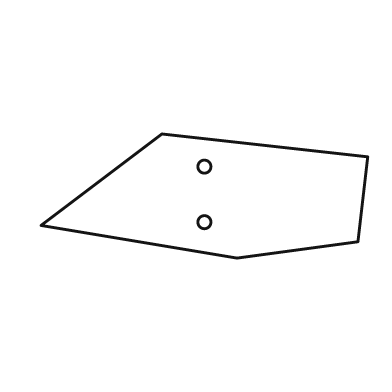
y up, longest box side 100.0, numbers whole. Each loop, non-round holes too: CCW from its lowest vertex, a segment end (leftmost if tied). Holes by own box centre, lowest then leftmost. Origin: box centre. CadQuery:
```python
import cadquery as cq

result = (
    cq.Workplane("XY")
    .moveTo(10.0, -19.0)
    .lineTo(47.0, -14.0)
    .lineTo(50.0, 12.0)
    .lineTo(-13.0, 19.0)
    .lineTo(-50.0, -9.0)
    .close()
    .moveTo(0.0, -8.0)
    .circle(2.0)
    .moveTo(0.0, 9.0)
    .circle(2.0)
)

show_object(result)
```